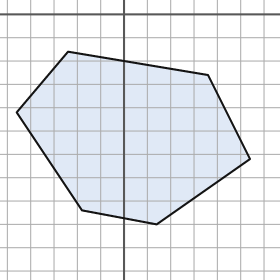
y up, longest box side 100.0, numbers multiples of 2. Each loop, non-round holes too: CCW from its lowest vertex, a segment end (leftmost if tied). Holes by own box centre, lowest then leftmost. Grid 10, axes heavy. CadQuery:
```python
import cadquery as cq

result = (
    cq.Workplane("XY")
    .moveTo(14.0, -90.0)
    .lineTo(54.0, -62.0)
    .lineTo(36.0, -26.0)
    .lineTo(-24.0, -16.0)
    .lineTo(-46.0, -42.0)
    .lineTo(-18.0, -84.0)
    .close()
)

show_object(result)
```